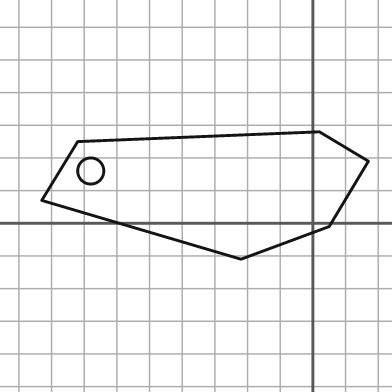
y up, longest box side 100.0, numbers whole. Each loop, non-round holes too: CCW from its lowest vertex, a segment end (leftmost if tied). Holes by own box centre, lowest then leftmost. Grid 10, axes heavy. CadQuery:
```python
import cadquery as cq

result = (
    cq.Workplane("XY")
    .moveTo(-22.0, -11.0)
    .lineTo(5.0, -1.0)
    .lineTo(17.0, 19.0)
    .lineTo(2.0, 28.0)
    .lineTo(-72.0, 25.0)
    .lineTo(-83.0, 7.0)
    .close()
    .moveTo(-68.0, 16.0)
    .circle(4.0)
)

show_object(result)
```